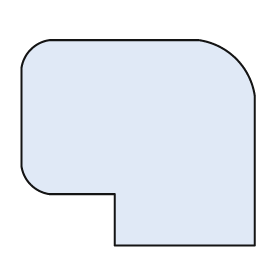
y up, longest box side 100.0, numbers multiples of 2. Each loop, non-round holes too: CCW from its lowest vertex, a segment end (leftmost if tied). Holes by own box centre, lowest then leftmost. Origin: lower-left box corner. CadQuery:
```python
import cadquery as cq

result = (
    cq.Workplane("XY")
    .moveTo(40.0, 0.0)
    .lineTo(100.0, 0.0)
    .lineTo(100.0, 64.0)
    .threePointArc((92.0, 80.0), (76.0, 88.0))
    .lineTo(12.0, 88.0)
    .threePointArc((4.0, 84.0), (0.0, 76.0))
    .lineTo(0.0, 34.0)
    .threePointArc((4.0, 26.0), (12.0, 22.0))
    .lineTo(40.0, 22.0)
    .close()
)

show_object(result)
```